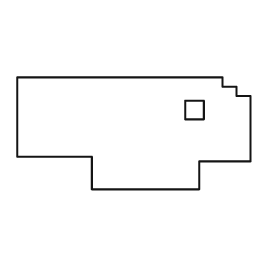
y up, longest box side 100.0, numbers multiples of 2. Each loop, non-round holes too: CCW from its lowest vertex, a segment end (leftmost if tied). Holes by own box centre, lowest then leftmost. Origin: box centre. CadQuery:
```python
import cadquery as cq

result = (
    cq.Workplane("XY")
    .moveTo(-18.0, -24.0)
    .lineTo(28.0, -24.0)
    .lineTo(28.0, -12.0)
    .lineTo(50.0, -12.0)
    .lineTo(50.0, 16.0)
    .lineTo(44.0, 16.0)
    .lineTo(44.0, 20.0)
    .lineTo(38.0, 20.0)
    .lineTo(38.0, 24.0)
    .lineTo(-50.0, 24.0)
    .lineTo(-50.0, -10.0)
    .lineTo(-18.0, -10.0)
    .close()
    .moveTo(22.0, 6.0)
    .lineTo(30.0, 6.0)
    .lineTo(30.0, 14.0)
    .lineTo(22.0, 14.0)
    .close()
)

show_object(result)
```